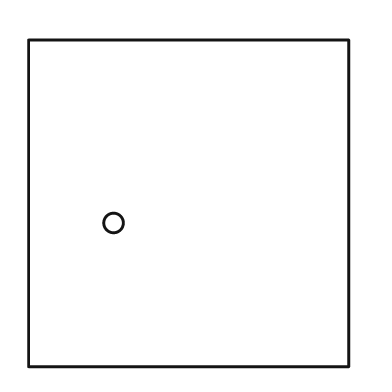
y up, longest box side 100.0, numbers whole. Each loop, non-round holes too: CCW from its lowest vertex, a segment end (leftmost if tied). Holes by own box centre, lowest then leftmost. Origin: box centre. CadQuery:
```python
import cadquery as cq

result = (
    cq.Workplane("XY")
    .moveTo(-49.0, -50.0)
    .lineTo(49.0, -50.0)
    .lineTo(49.0, 50.0)
    .lineTo(-49.0, 50.0)
    .close()
    .moveTo(-23.0, -6.0)
    .circle(3.0)
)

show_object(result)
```